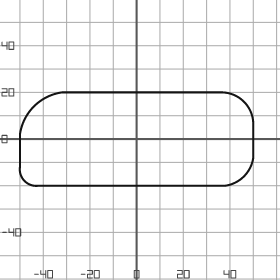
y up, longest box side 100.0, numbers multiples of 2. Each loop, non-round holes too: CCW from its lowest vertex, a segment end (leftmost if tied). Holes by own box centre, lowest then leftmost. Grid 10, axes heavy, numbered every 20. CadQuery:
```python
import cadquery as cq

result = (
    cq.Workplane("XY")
    .moveTo(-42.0, -20.0)
    .lineTo(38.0, -20.0)
    .threePointArc((46.0, -16.0), (50.0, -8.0))
    .lineTo(50.0, 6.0)
    .threePointArc((46.0, 16.0), (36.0, 20.0))
    .lineTo(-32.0, 20.0)
    .threePointArc((-44.0, 14.0), (-50.0, 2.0))
    .lineTo(-50.0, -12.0)
    .threePointArc((-48.0, -18.0), (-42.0, -20.0))
    .close()
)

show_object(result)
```